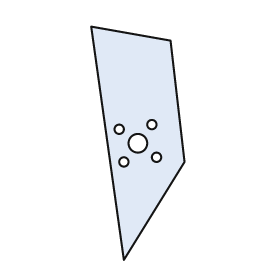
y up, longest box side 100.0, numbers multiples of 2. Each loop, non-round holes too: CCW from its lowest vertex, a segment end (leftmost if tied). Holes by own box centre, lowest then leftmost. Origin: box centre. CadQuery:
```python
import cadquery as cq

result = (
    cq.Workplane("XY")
    .moveTo(-6.0, -50.0)
    .lineTo(20.0, -8.0)
    .lineTo(14.0, 44.0)
    .lineTo(-20.0, 50.0)
    .close()
    .moveTo(-6.0, -8.0)
    .circle(2.0)
    .moveTo(8.0, -6.0)
    .circle(2.0)
    .moveTo(0.0, 0.0)
    .circle(4.0)
    .moveTo(-8.0, 6.0)
    .circle(2.0)
    .moveTo(6.0, 8.0)
    .circle(2.0)
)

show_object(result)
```